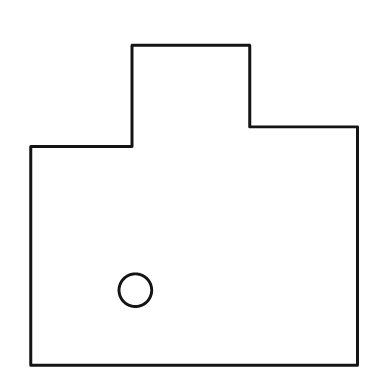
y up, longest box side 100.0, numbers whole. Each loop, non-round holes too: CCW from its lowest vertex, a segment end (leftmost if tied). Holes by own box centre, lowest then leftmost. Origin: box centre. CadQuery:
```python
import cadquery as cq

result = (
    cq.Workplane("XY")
    .moveTo(-50.0, -49.0)
    .lineTo(50.0, -49.0)
    .lineTo(50.0, 24.0)
    .lineTo(17.0, 24.0)
    .lineTo(17.0, 49.0)
    .lineTo(-19.0, 49.0)
    .lineTo(-19.0, 18.0)
    .lineTo(-50.0, 18.0)
    .close()
    .moveTo(-18.0, -26.0)
    .circle(5.0)
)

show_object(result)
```